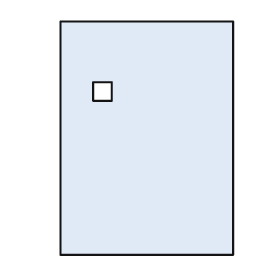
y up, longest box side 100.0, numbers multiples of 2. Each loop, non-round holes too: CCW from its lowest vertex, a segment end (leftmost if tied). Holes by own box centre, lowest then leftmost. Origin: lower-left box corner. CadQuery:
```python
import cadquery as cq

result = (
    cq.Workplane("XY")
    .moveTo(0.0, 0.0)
    .lineTo(74.0, 0.0)
    .lineTo(74.0, 100.0)
    .lineTo(0.0, 100.0)
    .close()
    .moveTo(14.0, 66.0)
    .lineTo(22.0, 66.0)
    .lineTo(22.0, 74.0)
    .lineTo(14.0, 74.0)
    .close()
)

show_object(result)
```